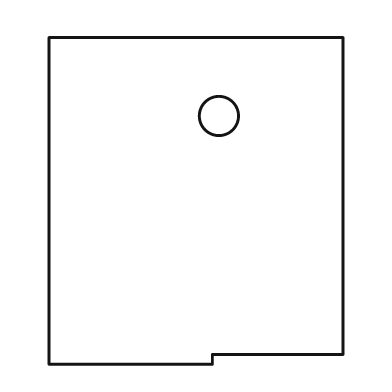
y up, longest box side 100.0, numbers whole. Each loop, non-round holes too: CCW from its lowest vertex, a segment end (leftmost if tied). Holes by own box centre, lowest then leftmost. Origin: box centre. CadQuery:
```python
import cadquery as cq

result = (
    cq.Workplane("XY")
    .moveTo(-45.0, -50.0)
    .lineTo(5.0, -50.0)
    .lineTo(5.0, -47.0)
    .lineTo(45.0, -47.0)
    .lineTo(45.0, 50.0)
    .lineTo(-45.0, 50.0)
    .close()
    .moveTo(7.0, 26.0)
    .circle(6.0)
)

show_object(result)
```